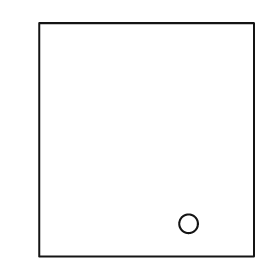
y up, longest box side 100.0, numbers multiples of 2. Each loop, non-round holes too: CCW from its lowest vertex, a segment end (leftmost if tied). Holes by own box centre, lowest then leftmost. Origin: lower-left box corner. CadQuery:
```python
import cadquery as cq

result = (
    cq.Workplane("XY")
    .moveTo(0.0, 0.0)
    .lineTo(92.0, 0.0)
    .lineTo(92.0, 100.0)
    .lineTo(0.0, 100.0)
    .close()
    .moveTo(64.0, 14.0)
    .circle(4.0)
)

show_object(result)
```